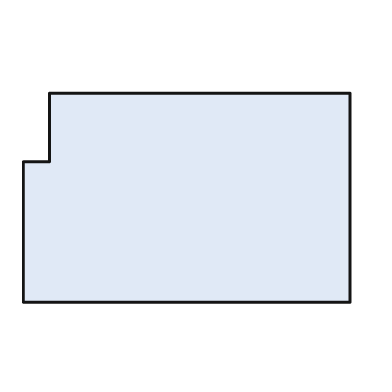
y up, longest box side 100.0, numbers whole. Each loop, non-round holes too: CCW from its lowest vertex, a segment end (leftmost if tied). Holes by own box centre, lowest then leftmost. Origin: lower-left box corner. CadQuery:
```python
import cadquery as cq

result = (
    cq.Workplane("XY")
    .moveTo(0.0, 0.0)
    .lineTo(100.0, 0.0)
    .lineTo(100.0, 64.0)
    .lineTo(8.0, 64.0)
    .lineTo(8.0, 43.0)
    .lineTo(0.0, 43.0)
    .close()
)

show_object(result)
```